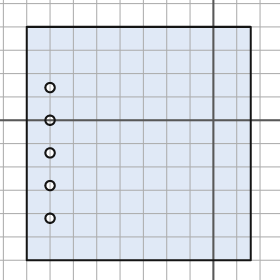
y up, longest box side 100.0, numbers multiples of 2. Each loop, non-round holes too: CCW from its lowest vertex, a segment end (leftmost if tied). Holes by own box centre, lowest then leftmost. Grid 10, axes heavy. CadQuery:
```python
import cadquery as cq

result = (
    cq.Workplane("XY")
    .moveTo(-80.0, -60.0)
    .lineTo(16.0, -60.0)
    .lineTo(16.0, 40.0)
    .lineTo(-80.0, 40.0)
    .close()
    .moveTo(-70.0, -42.0)
    .circle(2.0)
    .moveTo(-70.0, -28.0)
    .circle(2.0)
    .moveTo(-70.0, -14.0)
    .circle(2.0)
    .moveTo(-70.0, 0.0)
    .circle(2.0)
    .moveTo(-70.0, 14.0)
    .circle(2.0)
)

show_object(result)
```